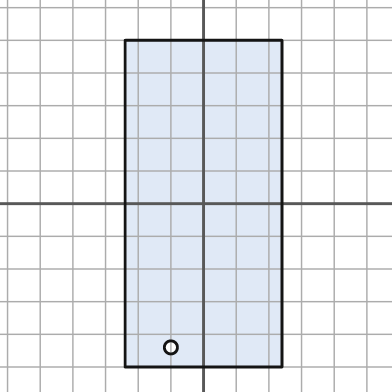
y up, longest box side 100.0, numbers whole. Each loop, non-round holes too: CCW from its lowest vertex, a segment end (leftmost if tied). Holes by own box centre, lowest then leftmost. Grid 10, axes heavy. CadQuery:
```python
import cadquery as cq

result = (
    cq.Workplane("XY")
    .moveTo(-24.0, -50.0)
    .lineTo(24.0, -50.0)
    .lineTo(24.0, 50.0)
    .lineTo(-24.0, 50.0)
    .close()
    .moveTo(-10.0, -44.0)
    .circle(2.0)
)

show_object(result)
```